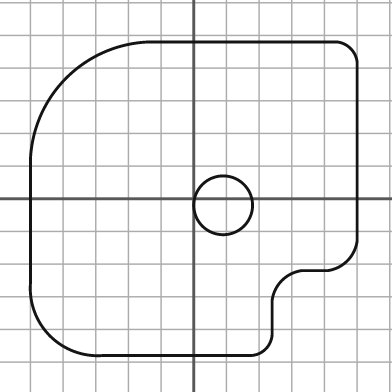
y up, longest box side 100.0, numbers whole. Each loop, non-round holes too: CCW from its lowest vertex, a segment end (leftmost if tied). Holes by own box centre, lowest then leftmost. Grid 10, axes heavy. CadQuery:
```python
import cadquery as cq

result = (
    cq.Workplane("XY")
    .moveTo(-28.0, -48.0)
    .lineTo(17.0, -48.0)
    .threePointArc((22.0, -46.0), (24.0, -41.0))
    .lineTo(24.0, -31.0)
    .threePointArc((27.0, -25.0), (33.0, -22.0))
    .lineTo(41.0, -22.0)
    .threePointArc((47.0, -19.0), (50.0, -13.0))
    .lineTo(50.0, 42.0)
    .threePointArc((48.0, 46.0), (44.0, 48.0))
    .lineTo(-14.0, 48.0)
    .threePointArc((-39.0, 37.0), (-50.0, 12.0))
    .lineTo(-50.0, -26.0)
    .threePointArc((-44.0, -42.0), (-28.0, -48.0))
    .close()
    .moveTo(9.0, -2.0)
    .circle(9.0)
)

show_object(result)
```